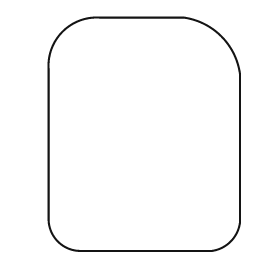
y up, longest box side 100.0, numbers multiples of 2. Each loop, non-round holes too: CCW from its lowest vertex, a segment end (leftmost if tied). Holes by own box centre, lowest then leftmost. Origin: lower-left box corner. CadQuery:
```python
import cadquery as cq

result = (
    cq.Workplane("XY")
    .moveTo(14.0, 0.0)
    .lineTo(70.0, 0.0)
    .threePointArc((78.0, 4.0), (82.0, 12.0))
    .lineTo(82.0, 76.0)
    .threePointArc((74.0, 92.0), (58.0, 100.0))
    .lineTo(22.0, 100.0)
    .threePointArc((6.0, 94.0), (0.0, 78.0))
    .lineTo(0.0, 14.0)
    .threePointArc((4.0, 4.0), (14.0, 0.0))
    .close()
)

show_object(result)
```